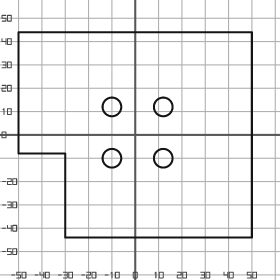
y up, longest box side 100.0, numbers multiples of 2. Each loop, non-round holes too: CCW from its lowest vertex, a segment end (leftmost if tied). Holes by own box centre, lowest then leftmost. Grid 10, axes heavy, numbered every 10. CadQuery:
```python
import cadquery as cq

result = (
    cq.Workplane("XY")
    .moveTo(-30.0, -44.0)
    .lineTo(50.0, -44.0)
    .lineTo(50.0, 44.0)
    .lineTo(-50.0, 44.0)
    .lineTo(-50.0, -8.0)
    .lineTo(-30.0, -8.0)
    .close()
    .moveTo(-10.0, -10.0)
    .circle(4.0)
    .moveTo(12.0, -10.0)
    .circle(4.0)
    .moveTo(-10.0, 12.0)
    .circle(4.0)
    .moveTo(12.0, 12.0)
    .circle(4.0)
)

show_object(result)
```